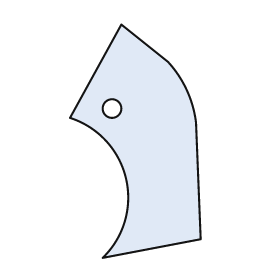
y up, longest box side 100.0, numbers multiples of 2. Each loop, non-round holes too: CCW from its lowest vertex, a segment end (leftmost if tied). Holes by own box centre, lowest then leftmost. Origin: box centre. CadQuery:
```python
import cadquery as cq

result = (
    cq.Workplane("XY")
    .moveTo(-14.0, -50.0)
    .lineTo(28.0, -42.0)
    .lineTo(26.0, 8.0)
    .threePointArc((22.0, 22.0), (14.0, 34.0))
    .lineTo(-6.0, 50.0)
    .lineTo(-28.0, 10.0)
    .threePointArc((-4.0, -16.0), (-14.0, -50.0))
    .close()
    .moveTo(-10.0, 14.0)
    .circle(4.0)
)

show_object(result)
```